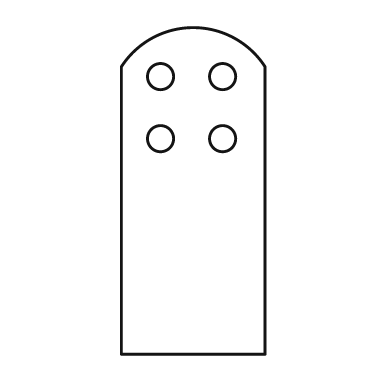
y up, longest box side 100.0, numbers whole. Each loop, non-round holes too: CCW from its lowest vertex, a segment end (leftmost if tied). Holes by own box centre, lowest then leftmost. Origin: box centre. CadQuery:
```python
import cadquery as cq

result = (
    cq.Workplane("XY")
    .moveTo(-22.0, -50.0)
    .lineTo(22.0, -50.0)
    .lineTo(22.0, 38.0)
    .threePointArc((0.0, 50.0), (-22.0, 38.0))
    .close()
    .moveTo(-10.0, 16.0)
    .circle(4.0)
    .moveTo(9.0, 16.0)
    .circle(4.0)
    .moveTo(-10.0, 35.0)
    .circle(4.0)
    .moveTo(9.0, 35.0)
    .circle(4.0)
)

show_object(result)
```